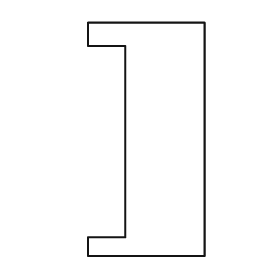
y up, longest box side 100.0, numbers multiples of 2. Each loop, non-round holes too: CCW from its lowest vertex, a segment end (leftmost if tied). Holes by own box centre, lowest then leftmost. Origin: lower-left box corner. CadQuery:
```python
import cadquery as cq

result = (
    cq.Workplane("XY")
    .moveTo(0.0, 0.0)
    .lineTo(50.0, 0.0)
    .lineTo(50.0, 100.0)
    .lineTo(0.0, 100.0)
    .lineTo(0.0, 90.0)
    .lineTo(16.0, 90.0)
    .lineTo(16.0, 8.0)
    .lineTo(0.0, 8.0)
    .close()
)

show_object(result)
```